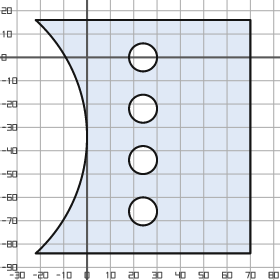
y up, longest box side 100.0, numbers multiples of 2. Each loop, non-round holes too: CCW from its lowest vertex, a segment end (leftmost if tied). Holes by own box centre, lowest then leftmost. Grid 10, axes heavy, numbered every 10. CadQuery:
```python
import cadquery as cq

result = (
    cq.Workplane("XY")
    .moveTo(-22.0, -84.0)
    .lineTo(70.0, -84.0)
    .lineTo(70.0, 16.0)
    .lineTo(-22.0, 16.0)
    .threePointArc((0.0, -34.0), (-22.0, -84.0))
    .close()
    .moveTo(24.0, -66.0)
    .circle(6.0)
    .moveTo(24.0, -44.0)
    .circle(6.0)
    .moveTo(24.0, -22.0)
    .circle(6.0)
    .moveTo(24.0, 0.0)
    .circle(6.0)
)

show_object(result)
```